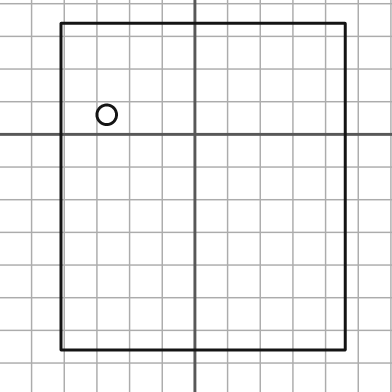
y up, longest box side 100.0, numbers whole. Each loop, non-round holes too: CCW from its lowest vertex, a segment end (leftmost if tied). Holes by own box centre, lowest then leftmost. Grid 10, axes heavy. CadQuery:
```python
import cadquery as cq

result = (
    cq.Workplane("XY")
    .moveTo(-41.0, -66.0)
    .lineTo(46.0, -66.0)
    .lineTo(46.0, 34.0)
    .lineTo(-41.0, 34.0)
    .close()
    .moveTo(-27.0, 6.0)
    .circle(3.0)
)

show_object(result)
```